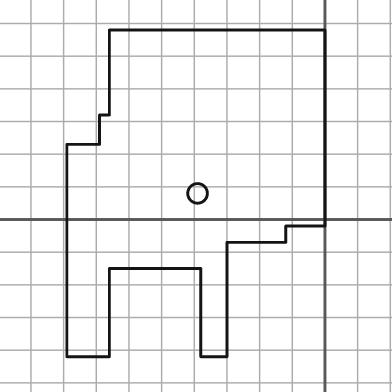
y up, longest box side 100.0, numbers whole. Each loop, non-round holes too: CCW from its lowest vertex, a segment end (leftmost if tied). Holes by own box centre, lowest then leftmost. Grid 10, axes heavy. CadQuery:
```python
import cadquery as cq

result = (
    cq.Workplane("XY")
    .moveTo(-79.0, -42.0)
    .lineTo(-66.0, -42.0)
    .lineTo(-66.0, -15.0)
    .lineTo(-38.0, -15.0)
    .lineTo(-38.0, -42.0)
    .lineTo(-30.0, -42.0)
    .lineTo(-30.0, -7.0)
    .lineTo(-12.0, -7.0)
    .lineTo(-12.0, -2.0)
    .lineTo(0.0, -2.0)
    .lineTo(0.0, 58.0)
    .lineTo(-66.0, 58.0)
    .lineTo(-66.0, 32.0)
    .lineTo(-69.0, 32.0)
    .lineTo(-69.0, 23.0)
    .lineTo(-79.0, 23.0)
    .close()
    .moveTo(-39.0, 8.0)
    .circle(3.0)
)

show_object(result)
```